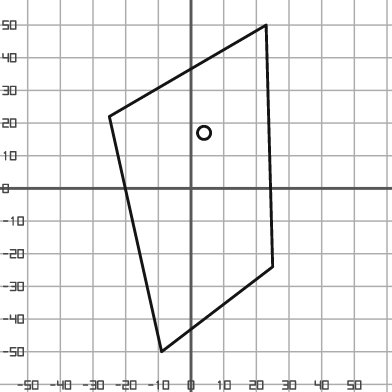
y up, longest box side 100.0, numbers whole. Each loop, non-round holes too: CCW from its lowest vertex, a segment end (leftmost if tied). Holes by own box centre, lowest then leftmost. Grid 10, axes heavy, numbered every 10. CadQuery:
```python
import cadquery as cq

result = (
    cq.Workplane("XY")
    .moveTo(-9.0, -50.0)
    .lineTo(25.0, -24.0)
    .lineTo(23.0, 50.0)
    .lineTo(-25.0, 22.0)
    .close()
    .moveTo(4.0, 17.0)
    .circle(2.0)
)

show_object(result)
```